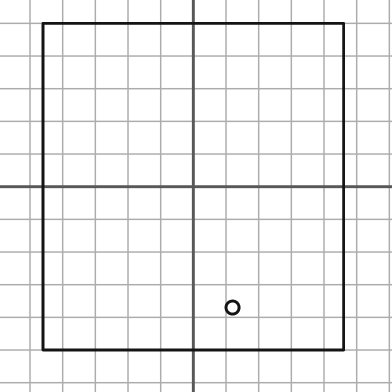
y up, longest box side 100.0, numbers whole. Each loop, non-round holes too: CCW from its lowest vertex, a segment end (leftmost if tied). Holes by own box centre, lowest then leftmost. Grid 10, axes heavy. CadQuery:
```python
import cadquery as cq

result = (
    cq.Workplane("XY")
    .moveTo(-46.0, -50.0)
    .lineTo(46.0, -50.0)
    .lineTo(46.0, 50.0)
    .lineTo(-46.0, 50.0)
    .close()
    .moveTo(12.0, -37.0)
    .circle(2.0)
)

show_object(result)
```